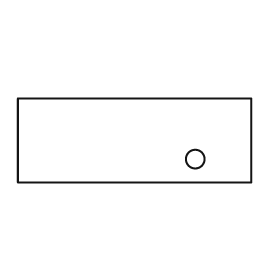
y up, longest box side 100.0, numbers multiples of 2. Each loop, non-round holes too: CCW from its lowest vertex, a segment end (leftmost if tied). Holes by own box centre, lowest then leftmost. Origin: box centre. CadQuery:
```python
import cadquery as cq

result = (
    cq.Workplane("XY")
    .moveTo(-50.0, -18.0)
    .lineTo(50.0, -18.0)
    .lineTo(50.0, 18.0)
    .lineTo(-50.0, 18.0)
    .close()
    .moveTo(26.0, -8.0)
    .circle(4.0)
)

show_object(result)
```